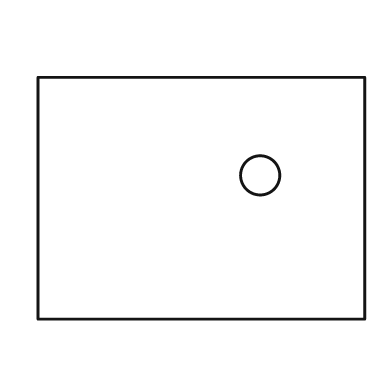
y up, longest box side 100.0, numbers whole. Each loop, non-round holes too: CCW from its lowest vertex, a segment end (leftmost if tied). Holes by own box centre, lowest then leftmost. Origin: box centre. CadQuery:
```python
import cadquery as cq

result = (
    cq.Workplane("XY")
    .moveTo(-50.0, -37.0)
    .lineTo(50.0, -37.0)
    .lineTo(50.0, 37.0)
    .lineTo(-50.0, 37.0)
    .close()
    .moveTo(18.0, 7.0)
    .circle(6.0)
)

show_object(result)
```